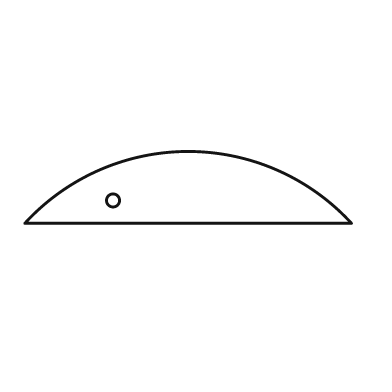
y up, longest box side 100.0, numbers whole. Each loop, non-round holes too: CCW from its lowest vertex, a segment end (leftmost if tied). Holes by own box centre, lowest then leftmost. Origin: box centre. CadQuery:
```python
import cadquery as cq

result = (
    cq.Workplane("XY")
    .moveTo(-50.0, -11.0)
    .lineTo(50.0, -11.0)
    .threePointArc((0.0, 11.0), (-50.0, -11.0))
    .close()
    .moveTo(-23.0, -4.0)
    .circle(2.0)
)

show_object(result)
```